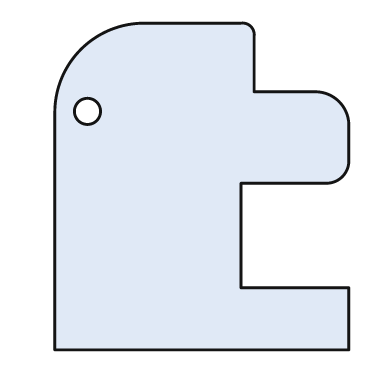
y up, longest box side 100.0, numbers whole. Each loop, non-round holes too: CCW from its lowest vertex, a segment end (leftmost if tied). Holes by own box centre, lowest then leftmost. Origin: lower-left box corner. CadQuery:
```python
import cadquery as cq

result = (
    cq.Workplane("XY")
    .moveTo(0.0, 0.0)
    .lineTo(90.0, 0.0)
    .lineTo(90.0, 19.0)
    .lineTo(57.0, 19.0)
    .lineTo(57.0, 51.0)
    .lineTo(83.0, 51.0)
    .threePointArc((88.0, 53.0), (90.0, 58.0))
    .lineTo(90.0, 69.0)
    .threePointArc((87.0, 76.0), (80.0, 79.0))
    .lineTo(61.0, 79.0)
    .lineTo(61.0, 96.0)
    .threePointArc((60.0, 99.0), (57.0, 100.0))
    .lineTo(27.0, 100.0)
    .threePointArc((8.0, 92.0), (0.0, 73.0))
    .close()
    .moveTo(10.0, 73.0)
    .circle(4.0)
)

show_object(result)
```